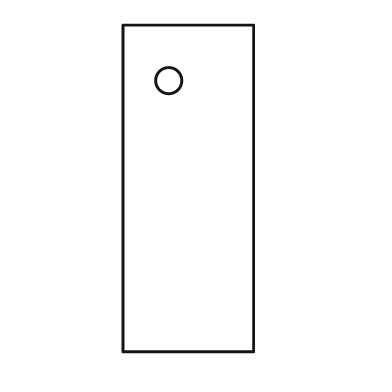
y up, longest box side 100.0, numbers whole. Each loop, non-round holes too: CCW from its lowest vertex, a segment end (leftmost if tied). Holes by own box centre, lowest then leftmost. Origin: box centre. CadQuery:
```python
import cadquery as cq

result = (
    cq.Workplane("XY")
    .moveTo(-20.0, -50.0)
    .lineTo(20.0, -50.0)
    .lineTo(20.0, 50.0)
    .lineTo(-20.0, 50.0)
    .close()
    .moveTo(-6.0, 33.0)
    .circle(4.0)
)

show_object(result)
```